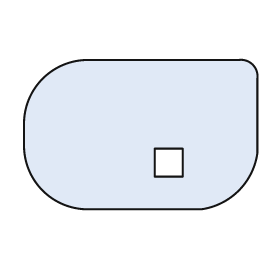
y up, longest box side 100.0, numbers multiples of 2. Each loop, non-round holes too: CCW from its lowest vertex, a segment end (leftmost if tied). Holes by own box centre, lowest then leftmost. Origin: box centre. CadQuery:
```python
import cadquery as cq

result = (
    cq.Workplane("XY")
    .moveTo(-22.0, -32.0)
    .lineTo(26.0, -32.0)
    .threePointArc((42.0, -24.0), (50.0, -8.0))
    .lineTo(50.0, 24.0)
    .threePointArc((48.0, 30.0), (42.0, 32.0))
    .lineTo(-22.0, 32.0)
    .threePointArc((-42.0, 24.0), (-50.0, 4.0))
    .lineTo(-50.0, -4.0)
    .threePointArc((-42.0, -24.0), (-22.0, -32.0))
    .close()
    .moveTo(6.0, -18.0)
    .lineTo(18.0, -18.0)
    .lineTo(18.0, -6.0)
    .lineTo(6.0, -6.0)
    .close()
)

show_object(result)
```